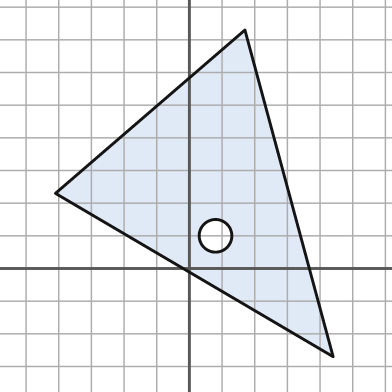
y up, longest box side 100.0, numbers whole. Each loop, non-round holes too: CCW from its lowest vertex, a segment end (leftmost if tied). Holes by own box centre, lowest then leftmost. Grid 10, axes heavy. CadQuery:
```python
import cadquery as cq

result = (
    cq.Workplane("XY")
    .moveTo(44.0, -27.0)
    .lineTo(17.0, 73.0)
    .lineTo(-41.0, 23.0)
    .close()
    .moveTo(8.0, 10.0)
    .circle(5.0)
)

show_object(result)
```